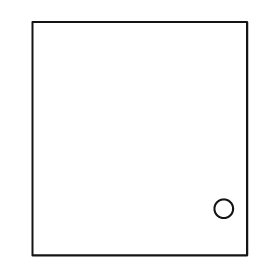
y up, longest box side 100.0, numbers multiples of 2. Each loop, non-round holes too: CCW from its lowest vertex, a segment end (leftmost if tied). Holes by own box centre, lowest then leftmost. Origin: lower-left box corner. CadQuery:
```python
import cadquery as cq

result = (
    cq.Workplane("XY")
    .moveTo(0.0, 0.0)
    .lineTo(92.0, 0.0)
    .lineTo(92.0, 100.0)
    .lineTo(0.0, 100.0)
    .close()
    .moveTo(82.0, 20.0)
    .circle(4.0)
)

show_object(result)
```